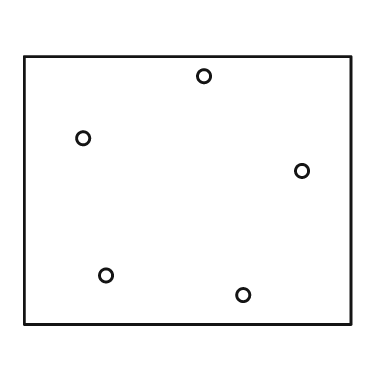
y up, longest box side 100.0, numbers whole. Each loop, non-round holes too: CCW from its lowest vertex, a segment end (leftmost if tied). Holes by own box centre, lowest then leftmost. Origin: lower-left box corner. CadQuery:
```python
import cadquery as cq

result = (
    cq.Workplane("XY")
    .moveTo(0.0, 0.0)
    .lineTo(100.0, 0.0)
    .lineTo(100.0, 82.0)
    .lineTo(0.0, 82.0)
    .close()
    .moveTo(67.0, 9.0)
    .circle(2.0)
    .moveTo(25.0, 15.0)
    .circle(2.0)
    .moveTo(85.0, 47.0)
    .circle(2.0)
    .moveTo(18.0, 57.0)
    .circle(2.0)
    .moveTo(55.0, 76.0)
    .circle(2.0)
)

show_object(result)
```